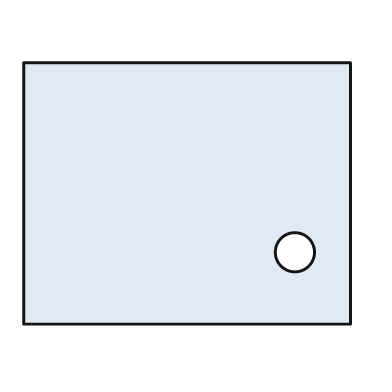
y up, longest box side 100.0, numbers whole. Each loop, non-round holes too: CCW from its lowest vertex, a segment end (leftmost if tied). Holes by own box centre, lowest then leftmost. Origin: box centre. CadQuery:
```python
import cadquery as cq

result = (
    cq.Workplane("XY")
    .moveTo(-50.0, -40.0)
    .lineTo(50.0, -40.0)
    .lineTo(50.0, 40.0)
    .lineTo(-50.0, 40.0)
    .close()
    .moveTo(33.0, -18.0)
    .circle(6.0)
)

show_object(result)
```